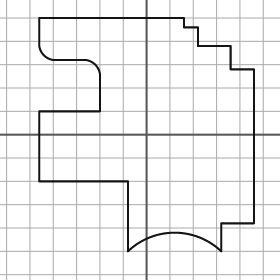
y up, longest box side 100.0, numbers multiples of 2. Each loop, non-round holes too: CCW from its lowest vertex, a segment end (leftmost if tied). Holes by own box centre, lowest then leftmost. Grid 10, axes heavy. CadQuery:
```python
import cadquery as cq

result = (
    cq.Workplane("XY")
    .moveTo(-8.0, -50.0)
    .threePointArc((12.0, -42.0), (32.0, -50.0))
    .lineTo(32.0, -38.0)
    .lineTo(46.0, -38.0)
    .lineTo(46.0, 28.0)
    .lineTo(36.0, 28.0)
    .lineTo(36.0, 38.0)
    .lineTo(22.0, 38.0)
    .lineTo(22.0, 46.0)
    .lineTo(16.0, 46.0)
    .lineTo(16.0, 50.0)
    .lineTo(-46.0, 50.0)
    .lineTo(-46.0, 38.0)
    .threePointArc((-44.0, 34.0), (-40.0, 32.0))
    .lineTo(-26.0, 32.0)
    .threePointArc((-22.0, 30.0), (-20.0, 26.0))
    .lineTo(-20.0, 10.0)
    .lineTo(-46.0, 10.0)
    .lineTo(-46.0, -20.0)
    .lineTo(-8.0, -20.0)
    .close()
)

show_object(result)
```